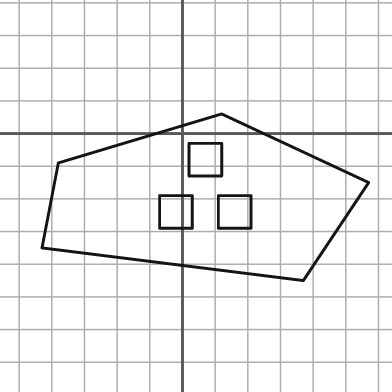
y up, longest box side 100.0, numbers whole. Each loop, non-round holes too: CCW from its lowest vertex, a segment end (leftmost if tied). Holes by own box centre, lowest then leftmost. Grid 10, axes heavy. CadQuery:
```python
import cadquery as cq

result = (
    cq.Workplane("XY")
    .moveTo(37.0, -45.0)
    .lineTo(57.0, -15.0)
    .lineTo(12.0, 6.0)
    .lineTo(-38.0, -9.0)
    .lineTo(-43.0, -35.0)
    .close()
    .moveTo(-7.0, -29.0)
    .lineTo(3.0, -29.0)
    .lineTo(3.0, -19.0)
    .lineTo(-7.0, -19.0)
    .close()
    .moveTo(11.0, -29.0)
    .lineTo(21.0, -29.0)
    .lineTo(21.0, -19.0)
    .lineTo(11.0, -19.0)
    .close()
    .moveTo(2.0, -13.0)
    .lineTo(12.0, -13.0)
    .lineTo(12.0, -3.0)
    .lineTo(2.0, -3.0)
    .close()
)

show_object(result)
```